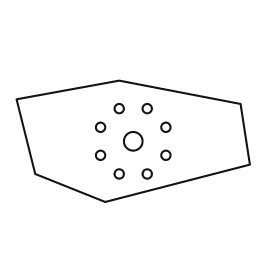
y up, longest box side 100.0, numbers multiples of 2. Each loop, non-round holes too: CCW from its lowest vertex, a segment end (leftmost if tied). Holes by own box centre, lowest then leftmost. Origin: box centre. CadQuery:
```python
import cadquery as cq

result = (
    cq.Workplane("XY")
    .moveTo(-12.0, -26.0)
    .lineTo(50.0, -10.0)
    .lineTo(46.0, 16.0)
    .lineTo(-6.0, 26.0)
    .lineTo(-50.0, 18.0)
    .lineTo(-42.0, -14.0)
    .close()
    .moveTo(-6.0, -14.0)
    .circle(2.0)
    .moveTo(6.0, -14.0)
    .circle(2.0)
    .moveTo(-14.0, -6.0)
    .circle(2.0)
    .moveTo(14.0, -6.0)
    .circle(2.0)
    .moveTo(0.0, 0.0)
    .circle(4.0)
    .moveTo(-14.0, 6.0)
    .circle(2.0)
    .moveTo(14.0, 6.0)
    .circle(2.0)
    .moveTo(-6.0, 14.0)
    .circle(2.0)
    .moveTo(6.0, 14.0)
    .circle(2.0)
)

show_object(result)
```